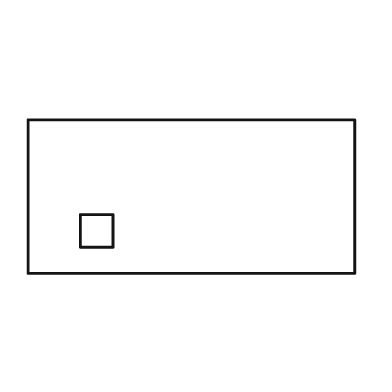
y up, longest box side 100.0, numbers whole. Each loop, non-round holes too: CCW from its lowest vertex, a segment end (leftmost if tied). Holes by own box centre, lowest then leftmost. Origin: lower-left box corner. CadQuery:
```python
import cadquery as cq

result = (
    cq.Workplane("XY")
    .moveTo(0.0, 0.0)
    .lineTo(100.0, 0.0)
    .lineTo(100.0, 47.0)
    .lineTo(0.0, 47.0)
    .close()
    .moveTo(16.0, 8.0)
    .lineTo(26.0, 8.0)
    .lineTo(26.0, 18.0)
    .lineTo(16.0, 18.0)
    .close()
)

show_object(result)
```